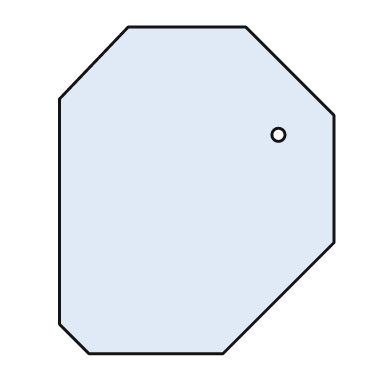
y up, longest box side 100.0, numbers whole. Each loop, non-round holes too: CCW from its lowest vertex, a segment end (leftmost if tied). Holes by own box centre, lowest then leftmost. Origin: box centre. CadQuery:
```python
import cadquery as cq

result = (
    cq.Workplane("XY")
    .moveTo(-33.0, -50.0)
    .lineTo(8.0, -50.0)
    .lineTo(42.0, -16.0)
    .lineTo(42.0, 23.0)
    .lineTo(15.0, 50.0)
    .lineTo(-21.0, 50.0)
    .lineTo(-42.0, 28.0)
    .lineTo(-42.0, -41.0)
    .close()
    .moveTo(25.0, 17.0)
    .circle(2.0)
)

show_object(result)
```